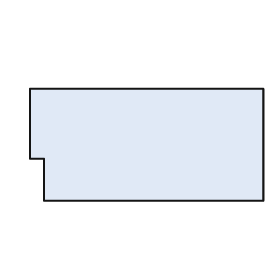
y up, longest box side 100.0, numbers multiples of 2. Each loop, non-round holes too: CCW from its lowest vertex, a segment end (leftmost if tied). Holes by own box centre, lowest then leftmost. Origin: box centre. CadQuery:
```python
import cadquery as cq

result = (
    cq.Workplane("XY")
    .moveTo(-44.0, -24.0)
    .lineTo(50.0, -24.0)
    .lineTo(50.0, 24.0)
    .lineTo(-50.0, 24.0)
    .lineTo(-50.0, -6.0)
    .lineTo(-44.0, -6.0)
    .close()
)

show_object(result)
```